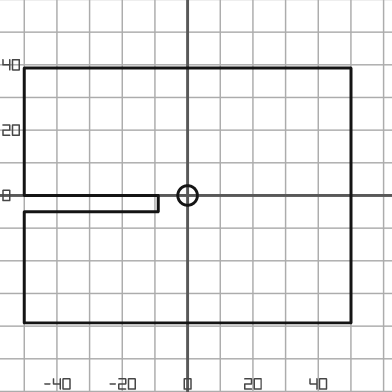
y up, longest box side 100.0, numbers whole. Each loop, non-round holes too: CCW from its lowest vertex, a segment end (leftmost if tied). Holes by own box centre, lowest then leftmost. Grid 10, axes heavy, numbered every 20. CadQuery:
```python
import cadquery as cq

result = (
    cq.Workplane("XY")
    .moveTo(-50.0, -39.0)
    .lineTo(50.0, -39.0)
    .lineTo(50.0, 39.0)
    .lineTo(-50.0, 39.0)
    .lineTo(-50.0, 0.0)
    .lineTo(-9.0, 0.0)
    .lineTo(-9.0, -5.0)
    .lineTo(-50.0, -5.0)
    .close()
    .moveTo(0.0, 0.0)
    .circle(3.0)
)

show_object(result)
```